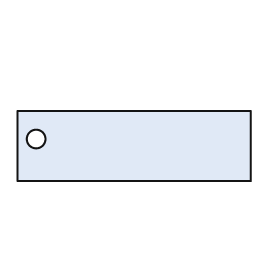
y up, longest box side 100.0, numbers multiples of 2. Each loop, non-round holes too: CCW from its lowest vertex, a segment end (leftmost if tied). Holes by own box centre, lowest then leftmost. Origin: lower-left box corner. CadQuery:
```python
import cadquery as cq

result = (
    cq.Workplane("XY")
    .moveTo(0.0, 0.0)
    .lineTo(100.0, 0.0)
    .lineTo(100.0, 30.0)
    .lineTo(0.0, 30.0)
    .close()
    .moveTo(8.0, 18.0)
    .circle(4.0)
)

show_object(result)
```